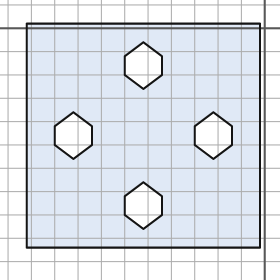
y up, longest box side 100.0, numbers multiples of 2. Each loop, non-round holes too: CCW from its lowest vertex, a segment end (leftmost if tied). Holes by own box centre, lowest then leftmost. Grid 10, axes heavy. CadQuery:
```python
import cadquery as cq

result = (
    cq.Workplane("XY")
    .moveTo(-102.0, -94.0)
    .lineTo(-2.0, -94.0)
    .lineTo(-2.0, 2.0)
    .lineTo(-102.0, 2.0)
    .close()
    .moveTo(-52.0, -86.0)
    .lineTo(-44.0, -80.0)
    .lineTo(-44.0, -72.0)
    .lineTo(-52.0, -66.0)
    .lineTo(-60.0, -72.0)
    .lineTo(-60.0, -80.0)
    .close()
    .moveTo(-82.0, -56.0)
    .lineTo(-74.0, -50.0)
    .lineTo(-74.0, -42.0)
    .lineTo(-82.0, -36.0)
    .lineTo(-90.0, -42.0)
    .lineTo(-90.0, -50.0)
    .close()
    .moveTo(-22.0, -56.0)
    .lineTo(-14.0, -50.0)
    .lineTo(-14.0, -42.0)
    .lineTo(-22.0, -36.0)
    .lineTo(-30.0, -42.0)
    .lineTo(-30.0, -50.0)
    .close()
    .moveTo(-52.0, -26.0)
    .lineTo(-44.0, -20.0)
    .lineTo(-44.0, -12.0)
    .lineTo(-52.0, -6.0)
    .lineTo(-60.0, -12.0)
    .lineTo(-60.0, -20.0)
    .close()
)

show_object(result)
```